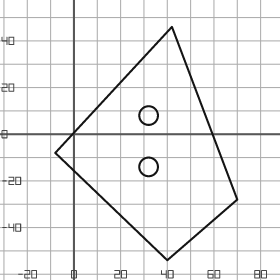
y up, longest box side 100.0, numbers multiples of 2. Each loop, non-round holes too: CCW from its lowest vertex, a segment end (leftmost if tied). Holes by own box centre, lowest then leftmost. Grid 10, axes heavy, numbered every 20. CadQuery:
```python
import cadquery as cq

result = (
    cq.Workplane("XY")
    .moveTo(40.0, -54.0)
    .lineTo(70.0, -28.0)
    .lineTo(42.0, 46.0)
    .lineTo(-8.0, -8.0)
    .close()
    .moveTo(32.0, -14.0)
    .circle(4.0)
    .moveTo(32.0, 8.0)
    .circle(4.0)
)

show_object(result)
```